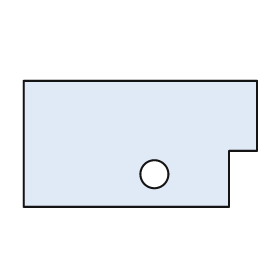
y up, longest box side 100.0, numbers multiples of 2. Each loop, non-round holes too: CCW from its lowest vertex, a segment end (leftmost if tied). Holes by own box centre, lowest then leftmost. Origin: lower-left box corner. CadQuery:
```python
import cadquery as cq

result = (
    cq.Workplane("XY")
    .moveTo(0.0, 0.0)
    .lineTo(88.0, 0.0)
    .lineTo(88.0, 24.0)
    .lineTo(100.0, 24.0)
    .lineTo(100.0, 54.0)
    .lineTo(0.0, 54.0)
    .close()
    .moveTo(56.0, 14.0)
    .circle(6.0)
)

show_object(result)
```